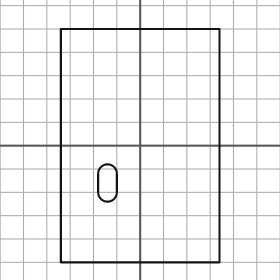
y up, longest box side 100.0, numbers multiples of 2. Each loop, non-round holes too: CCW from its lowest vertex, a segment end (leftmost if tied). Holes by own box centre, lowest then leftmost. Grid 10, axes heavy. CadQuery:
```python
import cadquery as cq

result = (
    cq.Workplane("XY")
    .moveTo(-34.0, -50.0)
    .lineTo(34.0, -50.0)
    .lineTo(34.0, 50.0)
    .lineTo(-34.0, 50.0)
    .close()
    .moveTo(-18.0, -20.0)
    .threePointArc((-14.0, -24.0), (-10.0, -20.0))
    .lineTo(-10.0, -12.0)
    .threePointArc((-14.0, -8.0), (-18.0, -12.0))
    .close()
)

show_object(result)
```